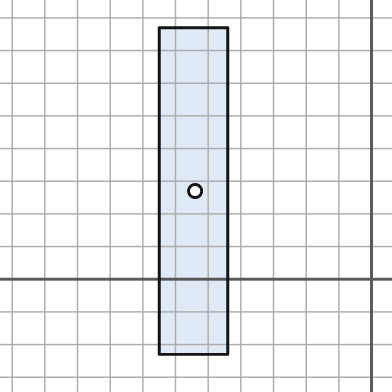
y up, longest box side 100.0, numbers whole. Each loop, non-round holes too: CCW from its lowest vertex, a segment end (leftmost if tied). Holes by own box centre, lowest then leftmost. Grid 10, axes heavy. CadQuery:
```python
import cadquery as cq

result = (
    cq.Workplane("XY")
    .moveTo(-65.0, -23.0)
    .lineTo(-44.0, -23.0)
    .lineTo(-44.0, 77.0)
    .lineTo(-65.0, 77.0)
    .close()
    .moveTo(-54.0, 27.0)
    .circle(2.0)
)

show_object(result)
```